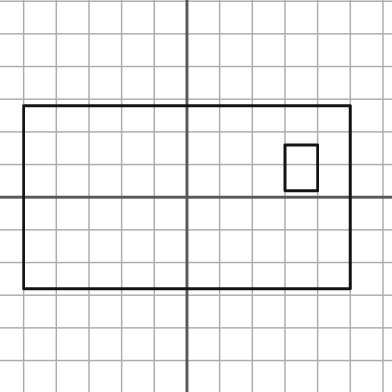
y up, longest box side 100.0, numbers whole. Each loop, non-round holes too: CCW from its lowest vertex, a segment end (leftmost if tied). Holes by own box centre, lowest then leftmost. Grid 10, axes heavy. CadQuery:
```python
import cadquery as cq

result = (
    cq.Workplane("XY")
    .moveTo(-50.0, -28.0)
    .lineTo(50.0, -28.0)
    .lineTo(50.0, 28.0)
    .lineTo(-50.0, 28.0)
    .close()
    .moveTo(30.0, 2.0)
    .lineTo(40.0, 2.0)
    .lineTo(40.0, 16.0)
    .lineTo(30.0, 16.0)
    .close()
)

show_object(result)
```